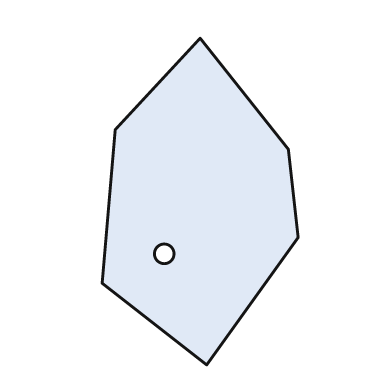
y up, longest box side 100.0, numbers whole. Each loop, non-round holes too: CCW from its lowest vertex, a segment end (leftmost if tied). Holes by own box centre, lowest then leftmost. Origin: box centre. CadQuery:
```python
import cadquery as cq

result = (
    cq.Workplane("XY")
    .moveTo(2.0, -50.0)
    .lineTo(30.0, -11.0)
    .lineTo(27.0, 16.0)
    .lineTo(0.0, 50.0)
    .lineTo(-26.0, 22.0)
    .lineTo(-30.0, -25.0)
    .close()
    .moveTo(-11.0, -16.0)
    .circle(3.0)
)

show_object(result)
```